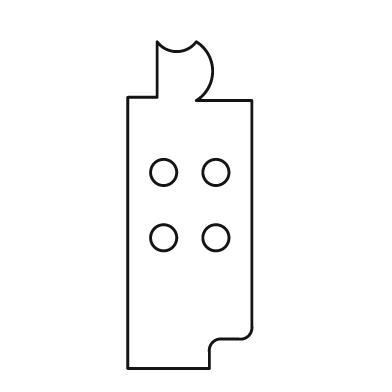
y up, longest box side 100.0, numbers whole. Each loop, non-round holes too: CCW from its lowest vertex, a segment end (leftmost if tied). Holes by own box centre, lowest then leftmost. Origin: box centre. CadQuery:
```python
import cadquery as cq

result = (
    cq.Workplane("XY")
    .moveTo(-19.0, -50.0)
    .lineTo(6.0, -50.0)
    .lineTo(6.0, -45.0)
    .threePointArc((7.0, -42.0), (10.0, -41.0))
    .lineTo(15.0, -41.0)
    .threePointArc((18.0, -40.0), (19.0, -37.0))
    .lineTo(19.0, 32.0)
    .lineTo(2.0, 32.0)
    .threePointArc((7.0, 41.0), (2.0, 50.0))
    .threePointArc((-4.0, 47.0), (-10.0, 50.0))
    .lineTo(-10.0, 33.0)
    .lineTo(-19.0, 33.0)
    .close()
    .moveTo(-8.0, -10.0)
    .circle(4.0)
    .moveTo(8.0, -10.0)
    .circle(4.0)
    .moveTo(-8.0, 10.0)
    .circle(4.0)
    .moveTo(8.0, 10.0)
    .circle(4.0)
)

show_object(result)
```